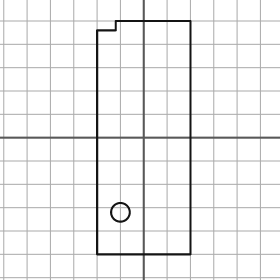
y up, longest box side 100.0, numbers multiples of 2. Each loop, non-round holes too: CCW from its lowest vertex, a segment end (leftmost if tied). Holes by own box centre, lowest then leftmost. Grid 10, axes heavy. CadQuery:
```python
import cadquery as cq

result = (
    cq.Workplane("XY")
    .moveTo(-20.0, -50.0)
    .lineTo(20.0, -50.0)
    .lineTo(20.0, 50.0)
    .lineTo(-12.0, 50.0)
    .lineTo(-12.0, 46.0)
    .lineTo(-20.0, 46.0)
    .close()
    .moveTo(-10.0, -32.0)
    .circle(4.0)
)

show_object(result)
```